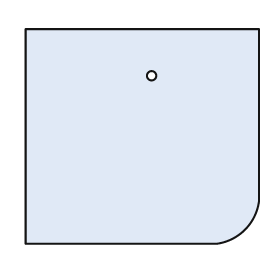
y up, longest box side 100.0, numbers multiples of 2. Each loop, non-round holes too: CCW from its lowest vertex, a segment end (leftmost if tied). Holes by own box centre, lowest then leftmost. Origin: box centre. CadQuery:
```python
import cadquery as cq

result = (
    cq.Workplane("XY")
    .moveTo(-50.0, -46.0)
    .lineTo(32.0, -46.0)
    .threePointArc((44.0, -40.0), (50.0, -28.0))
    .lineTo(50.0, 46.0)
    .lineTo(-50.0, 46.0)
    .close()
    .moveTo(4.0, 26.0)
    .circle(2.0)
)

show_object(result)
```